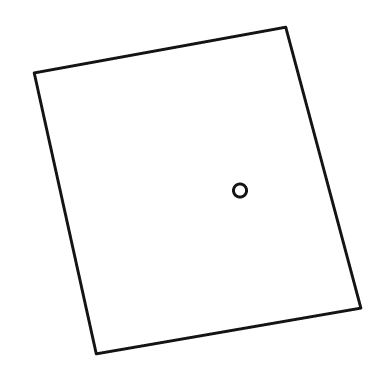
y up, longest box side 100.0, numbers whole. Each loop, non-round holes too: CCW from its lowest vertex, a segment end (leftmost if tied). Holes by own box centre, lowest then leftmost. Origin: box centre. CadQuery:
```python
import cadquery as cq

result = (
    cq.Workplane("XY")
    .moveTo(-31.0, -50.0)
    .lineTo(50.0, -36.0)
    .lineTo(27.0, 50.0)
    .lineTo(-50.0, 36.0)
    .close()
    .moveTo(13.0, 0.0)
    .circle(2.0)
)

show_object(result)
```